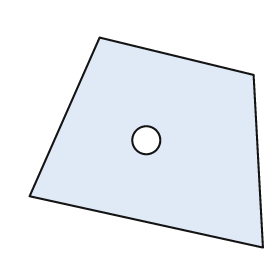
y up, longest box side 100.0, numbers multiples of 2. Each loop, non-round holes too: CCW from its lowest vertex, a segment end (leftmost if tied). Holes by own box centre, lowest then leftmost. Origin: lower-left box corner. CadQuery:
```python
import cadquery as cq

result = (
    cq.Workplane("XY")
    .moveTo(100.0, 0.0)
    .lineTo(96.0, 74.0)
    .lineTo(30.0, 90.0)
    .lineTo(0.0, 22.0)
    .close()
    .moveTo(50.0, 46.0)
    .circle(6.0)
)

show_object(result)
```